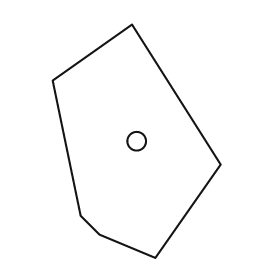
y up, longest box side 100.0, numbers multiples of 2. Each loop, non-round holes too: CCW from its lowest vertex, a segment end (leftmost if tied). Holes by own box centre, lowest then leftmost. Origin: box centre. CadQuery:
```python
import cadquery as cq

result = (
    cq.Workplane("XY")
    .moveTo(8.0, -50.0)
    .lineTo(36.0, -10.0)
    .lineTo(-2.0, 50.0)
    .lineTo(-36.0, 26.0)
    .lineTo(-24.0, -32.0)
    .lineTo(-16.0, -40.0)
    .close()
    .moveTo(0.0, 0.0)
    .circle(4.0)
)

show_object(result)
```